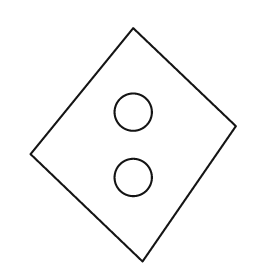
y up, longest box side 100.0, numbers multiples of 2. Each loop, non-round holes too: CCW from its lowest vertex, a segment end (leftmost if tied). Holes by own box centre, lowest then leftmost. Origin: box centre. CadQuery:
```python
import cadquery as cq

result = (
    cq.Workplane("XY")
    .moveTo(4.0, -50.0)
    .lineTo(44.0, 8.0)
    .lineTo(0.0, 50.0)
    .lineTo(-44.0, -4.0)
    .close()
    .moveTo(0.0, -14.0)
    .circle(8.0)
    .moveTo(0.0, 14.0)
    .circle(8.0)
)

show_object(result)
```